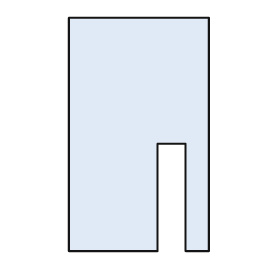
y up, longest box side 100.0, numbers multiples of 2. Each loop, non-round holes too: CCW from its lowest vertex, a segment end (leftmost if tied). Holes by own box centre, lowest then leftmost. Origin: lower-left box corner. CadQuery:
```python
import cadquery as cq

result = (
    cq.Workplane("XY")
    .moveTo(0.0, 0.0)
    .lineTo(38.0, 0.0)
    .lineTo(38.0, 46.0)
    .lineTo(50.0, 46.0)
    .lineTo(50.0, 0.0)
    .lineTo(60.0, 0.0)
    .lineTo(60.0, 100.0)
    .lineTo(0.0, 100.0)
    .close()
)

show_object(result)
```